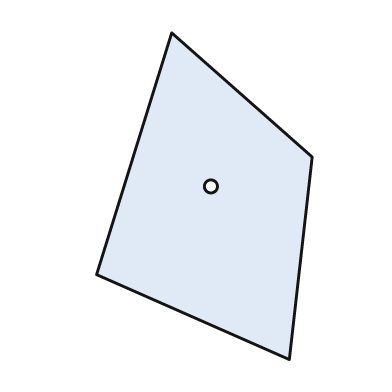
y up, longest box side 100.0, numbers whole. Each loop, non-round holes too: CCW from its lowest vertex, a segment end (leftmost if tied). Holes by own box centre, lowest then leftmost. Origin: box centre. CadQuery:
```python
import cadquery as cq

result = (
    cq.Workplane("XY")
    .moveTo(26.0, -50.0)
    .lineTo(33.0, 12.0)
    .lineTo(-10.0, 50.0)
    .lineTo(-33.0, -24.0)
    .close()
    .moveTo(2.0, 3.0)
    .circle(2.0)
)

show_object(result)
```